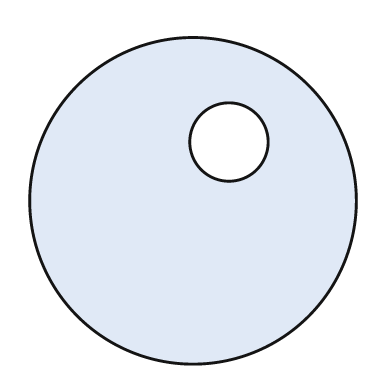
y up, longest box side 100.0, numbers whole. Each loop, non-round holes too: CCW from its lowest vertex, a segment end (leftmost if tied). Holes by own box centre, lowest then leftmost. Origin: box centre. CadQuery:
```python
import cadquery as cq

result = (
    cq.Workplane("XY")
    .moveTo(0.0, 0.0)
    .circle(50.0)
    .moveTo(11.0, 18.0)
    .circle(12.0)
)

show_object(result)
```